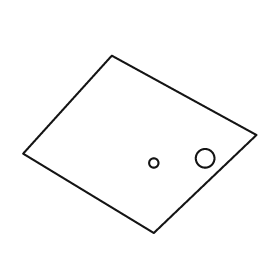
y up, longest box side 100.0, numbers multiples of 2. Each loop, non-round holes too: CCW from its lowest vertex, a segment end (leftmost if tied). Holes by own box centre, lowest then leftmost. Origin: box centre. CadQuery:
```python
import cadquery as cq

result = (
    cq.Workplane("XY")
    .moveTo(6.0, -38.0)
    .lineTo(50.0, 4.0)
    .lineTo(-12.0, 38.0)
    .lineTo(-50.0, -4.0)
    .close()
    .moveTo(6.0, -8.0)
    .circle(2.0)
    .moveTo(28.0, -6.0)
    .circle(4.0)
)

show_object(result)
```